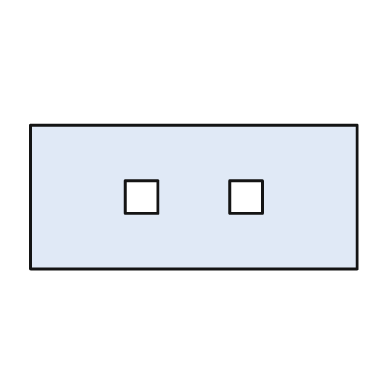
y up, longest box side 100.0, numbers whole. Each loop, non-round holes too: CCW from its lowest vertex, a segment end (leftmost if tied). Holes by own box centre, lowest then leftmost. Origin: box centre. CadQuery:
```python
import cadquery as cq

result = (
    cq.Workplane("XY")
    .moveTo(-50.0, -22.0)
    .lineTo(50.0, -22.0)
    .lineTo(50.0, 22.0)
    .lineTo(-50.0, 22.0)
    .close()
    .moveTo(-21.0, -5.0)
    .lineTo(-11.0, -5.0)
    .lineTo(-11.0, 5.0)
    .lineTo(-21.0, 5.0)
    .close()
    .moveTo(11.0, -5.0)
    .lineTo(21.0, -5.0)
    .lineTo(21.0, 5.0)
    .lineTo(11.0, 5.0)
    .close()
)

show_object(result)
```